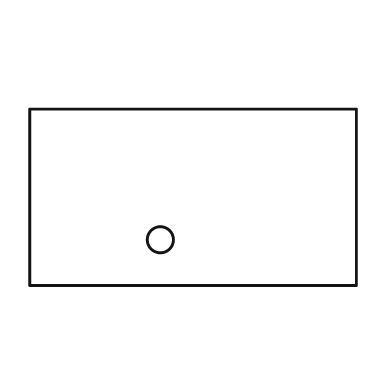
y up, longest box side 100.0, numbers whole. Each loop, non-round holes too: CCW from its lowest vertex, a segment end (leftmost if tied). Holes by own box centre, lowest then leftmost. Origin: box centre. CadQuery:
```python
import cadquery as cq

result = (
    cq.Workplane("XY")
    .moveTo(-50.0, -27.0)
    .lineTo(50.0, -27.0)
    .lineTo(50.0, 27.0)
    .lineTo(-50.0, 27.0)
    .close()
    .moveTo(-10.0, -13.0)
    .circle(4.0)
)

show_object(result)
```